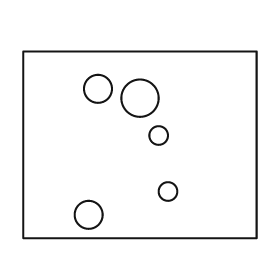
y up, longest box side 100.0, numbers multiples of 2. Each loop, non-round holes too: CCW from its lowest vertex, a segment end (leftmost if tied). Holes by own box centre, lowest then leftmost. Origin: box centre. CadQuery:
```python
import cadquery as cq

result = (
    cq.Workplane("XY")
    .moveTo(-50.0, -40.0)
    .lineTo(50.0, -40.0)
    .lineTo(50.0, 40.0)
    .lineTo(-50.0, 40.0)
    .close()
    .moveTo(-22.0, -30.0)
    .circle(6.0)
    .moveTo(12.0, -20.0)
    .circle(4.0)
    .moveTo(8.0, 4.0)
    .circle(4.0)
    .moveTo(0.0, 20.0)
    .circle(8.0)
    .moveTo(-18.0, 24.0)
    .circle(6.0)
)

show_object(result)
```